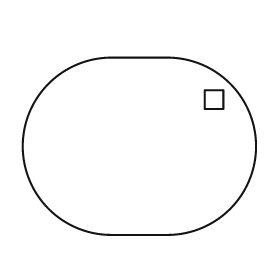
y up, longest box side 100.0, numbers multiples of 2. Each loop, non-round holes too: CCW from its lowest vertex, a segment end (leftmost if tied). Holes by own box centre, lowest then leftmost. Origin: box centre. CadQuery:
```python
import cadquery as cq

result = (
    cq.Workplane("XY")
    .moveTo(-12.0, -38.0)
    .lineTo(12.0, -38.0)
    .threePointArc((50.0, 0.0), (12.0, 38.0))
    .lineTo(-12.0, 38.0)
    .threePointArc((-50.0, 0.0), (-12.0, -38.0))
    .close()
    .moveTo(28.0, 16.0)
    .lineTo(36.0, 16.0)
    .lineTo(36.0, 24.0)
    .lineTo(28.0, 24.0)
    .close()
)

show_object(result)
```